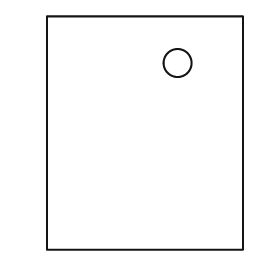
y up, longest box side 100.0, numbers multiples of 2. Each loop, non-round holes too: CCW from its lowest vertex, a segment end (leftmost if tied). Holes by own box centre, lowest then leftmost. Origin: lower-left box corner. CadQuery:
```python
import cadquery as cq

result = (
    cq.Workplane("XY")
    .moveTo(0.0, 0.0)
    .lineTo(84.0, 0.0)
    .lineTo(84.0, 100.0)
    .lineTo(0.0, 100.0)
    .close()
    .moveTo(56.0, 80.0)
    .circle(6.0)
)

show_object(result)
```